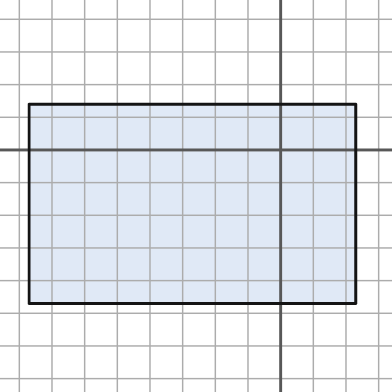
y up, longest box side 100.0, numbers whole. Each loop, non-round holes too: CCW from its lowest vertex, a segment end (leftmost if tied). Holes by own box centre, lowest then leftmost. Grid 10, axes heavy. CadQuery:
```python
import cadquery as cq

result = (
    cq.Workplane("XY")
    .moveTo(-77.0, -47.0)
    .lineTo(23.0, -47.0)
    .lineTo(23.0, 14.0)
    .lineTo(-77.0, 14.0)
    .close()
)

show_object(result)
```